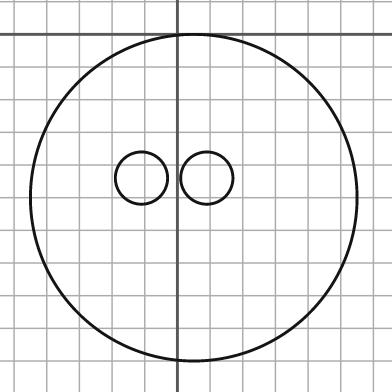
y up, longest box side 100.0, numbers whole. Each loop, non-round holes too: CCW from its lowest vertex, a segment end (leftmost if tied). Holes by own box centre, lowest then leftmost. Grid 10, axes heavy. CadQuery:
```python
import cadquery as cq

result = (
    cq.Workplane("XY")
    .moveTo(5.0, -50.0)
    .circle(50.0)
    .moveTo(-11.0, -44.0)
    .circle(8.0)
    .moveTo(9.0, -44.0)
    .circle(8.0)
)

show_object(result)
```